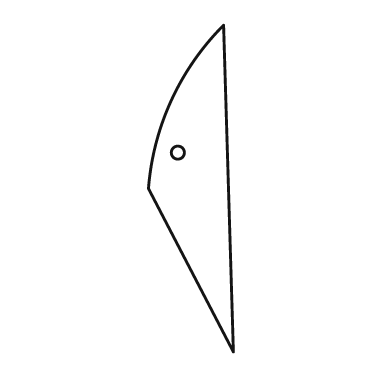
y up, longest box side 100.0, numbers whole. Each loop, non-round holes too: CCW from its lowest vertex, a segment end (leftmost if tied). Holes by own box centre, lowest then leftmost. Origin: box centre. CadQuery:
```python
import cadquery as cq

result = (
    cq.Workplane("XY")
    .moveTo(13.0, -50.0)
    .lineTo(10.0, 50.0)
    .threePointArc((-6.0, 27.0), (-13.0, 0.0))
    .close()
    .moveTo(-4.0, 11.0)
    .circle(2.0)
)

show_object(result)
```